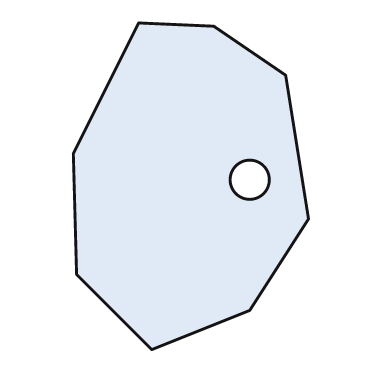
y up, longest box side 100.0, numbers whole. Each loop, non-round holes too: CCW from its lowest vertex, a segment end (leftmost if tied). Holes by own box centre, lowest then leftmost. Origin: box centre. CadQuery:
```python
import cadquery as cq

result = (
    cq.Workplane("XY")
    .moveTo(-12.0, -50.0)
    .lineTo(18.0, -38.0)
    .lineTo(36.0, -10.0)
    .lineTo(29.0, 34.0)
    .lineTo(7.0, 49.0)
    .lineTo(-16.0, 50.0)
    .lineTo(-36.0, 10.0)
    .lineTo(-35.0, -27.0)
    .close()
    .moveTo(18.0, 2.0)
    .circle(6.0)
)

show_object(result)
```